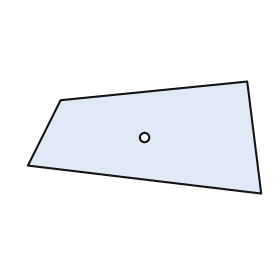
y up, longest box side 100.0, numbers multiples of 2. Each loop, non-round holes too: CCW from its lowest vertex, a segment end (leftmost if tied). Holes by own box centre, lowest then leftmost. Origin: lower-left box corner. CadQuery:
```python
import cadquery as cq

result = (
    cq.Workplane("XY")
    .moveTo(100.0, 0.0)
    .lineTo(94.0, 48.0)
    .lineTo(14.0, 40.0)
    .lineTo(0.0, 12.0)
    .close()
    .moveTo(50.0, 24.0)
    .circle(2.0)
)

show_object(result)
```